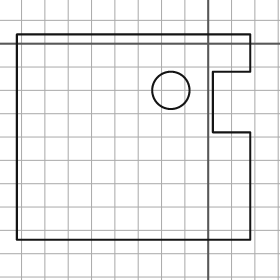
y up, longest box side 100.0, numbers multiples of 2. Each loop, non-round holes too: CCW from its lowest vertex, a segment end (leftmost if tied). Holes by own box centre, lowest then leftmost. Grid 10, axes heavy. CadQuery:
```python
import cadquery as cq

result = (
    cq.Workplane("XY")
    .moveTo(-82.0, -84.0)
    .lineTo(18.0, -84.0)
    .lineTo(18.0, -38.0)
    .lineTo(2.0, -38.0)
    .lineTo(2.0, -12.0)
    .lineTo(18.0, -12.0)
    .lineTo(18.0, 4.0)
    .lineTo(-82.0, 4.0)
    .close()
    .moveTo(-16.0, -20.0)
    .circle(8.0)
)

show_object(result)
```